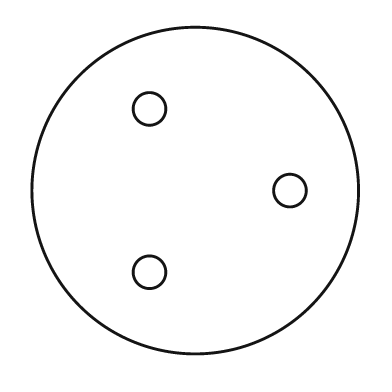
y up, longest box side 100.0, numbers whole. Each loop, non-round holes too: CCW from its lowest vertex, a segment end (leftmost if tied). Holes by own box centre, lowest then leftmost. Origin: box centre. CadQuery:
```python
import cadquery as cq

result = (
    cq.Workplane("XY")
    .moveTo(0.0, 0.0)
    .circle(50.0)
    .moveTo(-14.0, -25.0)
    .circle(5.0)
    .moveTo(29.0, 0.0)
    .circle(5.0)
    .moveTo(-14.0, 25.0)
    .circle(5.0)
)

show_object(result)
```